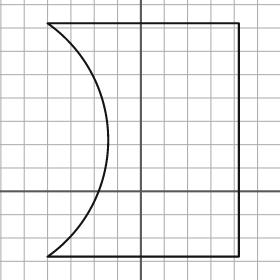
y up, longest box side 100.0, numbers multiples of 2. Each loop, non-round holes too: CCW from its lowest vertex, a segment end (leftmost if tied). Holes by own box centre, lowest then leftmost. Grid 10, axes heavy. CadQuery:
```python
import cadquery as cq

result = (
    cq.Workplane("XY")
    .moveTo(-40.0, -28.0)
    .lineTo(42.0, -28.0)
    .lineTo(42.0, 72.0)
    .lineTo(-40.0, 72.0)
    .threePointArc((-14.0, 22.0), (-40.0, -28.0))
    .close()
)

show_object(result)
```